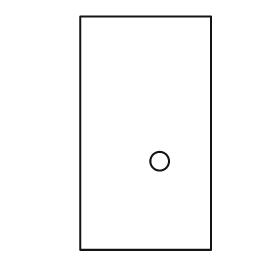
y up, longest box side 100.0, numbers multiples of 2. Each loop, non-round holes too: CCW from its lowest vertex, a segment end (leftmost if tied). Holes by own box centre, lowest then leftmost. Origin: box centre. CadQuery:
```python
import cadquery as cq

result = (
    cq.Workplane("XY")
    .moveTo(-28.0, -50.0)
    .lineTo(28.0, -50.0)
    .lineTo(28.0, 50.0)
    .lineTo(-28.0, 50.0)
    .close()
    .moveTo(6.0, -12.0)
    .circle(4.0)
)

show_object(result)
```